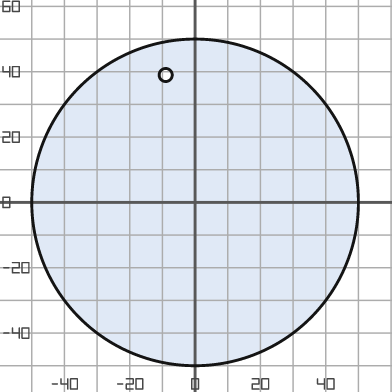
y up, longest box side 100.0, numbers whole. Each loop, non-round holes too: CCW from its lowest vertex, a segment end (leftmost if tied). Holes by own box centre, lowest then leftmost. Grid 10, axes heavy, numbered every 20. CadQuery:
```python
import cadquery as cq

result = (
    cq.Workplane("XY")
    .moveTo(0.0, 0.0)
    .circle(50.0)
    .moveTo(-9.0, 39.0)
    .circle(2.0)
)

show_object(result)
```